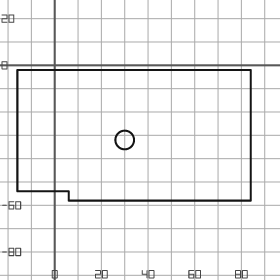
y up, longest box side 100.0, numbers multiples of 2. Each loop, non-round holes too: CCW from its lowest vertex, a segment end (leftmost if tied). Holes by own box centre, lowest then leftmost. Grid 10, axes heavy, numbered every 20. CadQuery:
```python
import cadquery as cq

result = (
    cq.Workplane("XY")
    .moveTo(6.0, -58.0)
    .lineTo(84.0, -58.0)
    .lineTo(84.0, -2.0)
    .lineTo(-16.0, -2.0)
    .lineTo(-16.0, -54.0)
    .lineTo(6.0, -54.0)
    .close()
    .moveTo(30.0, -32.0)
    .circle(4.0)
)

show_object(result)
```